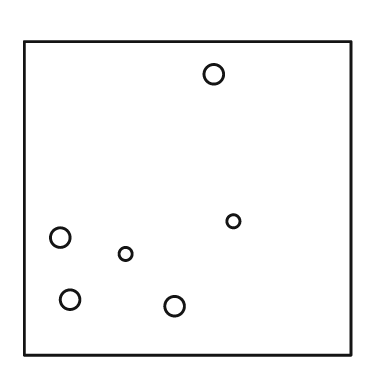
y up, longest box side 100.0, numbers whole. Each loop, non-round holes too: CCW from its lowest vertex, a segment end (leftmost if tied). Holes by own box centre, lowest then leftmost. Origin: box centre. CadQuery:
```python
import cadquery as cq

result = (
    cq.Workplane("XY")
    .moveTo(-50.0, -48.0)
    .lineTo(50.0, -48.0)
    .lineTo(50.0, 48.0)
    .lineTo(-50.0, 48.0)
    .close()
    .moveTo(-4.0, -33.0)
    .circle(3.0)
    .moveTo(-36.0, -31.0)
    .circle(3.0)
    .moveTo(-19.0, -17.0)
    .circle(2.0)
    .moveTo(-39.0, -12.0)
    .circle(3.0)
    .moveTo(14.0, -7.0)
    .circle(2.0)
    .moveTo(8.0, 38.0)
    .circle(3.0)
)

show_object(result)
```